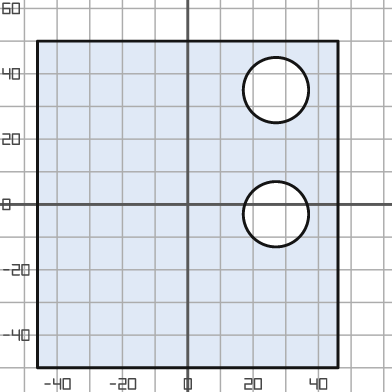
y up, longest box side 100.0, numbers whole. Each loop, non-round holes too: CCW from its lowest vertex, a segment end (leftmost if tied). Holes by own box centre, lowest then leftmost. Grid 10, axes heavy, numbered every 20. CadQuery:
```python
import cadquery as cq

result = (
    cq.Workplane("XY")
    .moveTo(-46.0, -50.0)
    .lineTo(46.0, -50.0)
    .lineTo(46.0, 50.0)
    .lineTo(-46.0, 50.0)
    .close()
    .moveTo(27.0, -3.0)
    .circle(10.0)
    .moveTo(27.0, 35.0)
    .circle(10.0)
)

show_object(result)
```